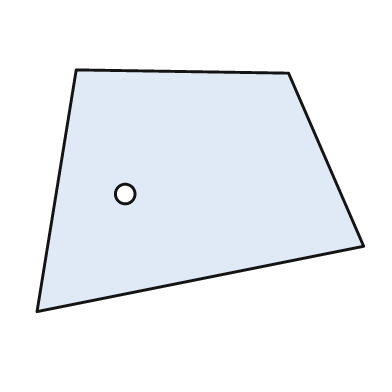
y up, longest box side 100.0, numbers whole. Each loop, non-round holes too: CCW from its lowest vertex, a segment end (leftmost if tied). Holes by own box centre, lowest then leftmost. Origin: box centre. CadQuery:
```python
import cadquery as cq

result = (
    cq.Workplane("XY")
    .moveTo(-50.0, -37.0)
    .lineTo(50.0, -17.0)
    .lineTo(27.0, 36.0)
    .lineTo(-38.0, 37.0)
    .close()
    .moveTo(-23.0, -1.0)
    .circle(3.0)
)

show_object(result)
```